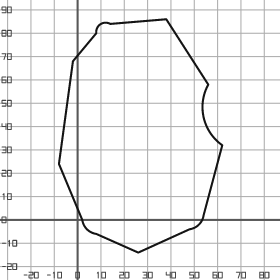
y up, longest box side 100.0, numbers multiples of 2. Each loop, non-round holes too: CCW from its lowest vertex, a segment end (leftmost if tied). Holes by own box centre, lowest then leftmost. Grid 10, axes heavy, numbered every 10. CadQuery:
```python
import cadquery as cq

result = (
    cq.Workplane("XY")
    .moveTo(26.0, -14.0)
    .lineTo(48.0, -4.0)
    .threePointArc((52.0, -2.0), (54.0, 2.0))
    .lineTo(62.0, 32.0)
    .threePointArc((54.0, 44.0), (56.0, 58.0))
    .lineTo(38.0, 86.0)
    .lineTo(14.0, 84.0)
    .threePointArc((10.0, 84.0), (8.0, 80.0))
    .lineTo(-2.0, 68.0)
    .lineTo(-8.0, 24.0)
    .lineTo(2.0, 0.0)
    .threePointArc((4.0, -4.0), (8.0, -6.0))
    .close()
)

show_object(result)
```